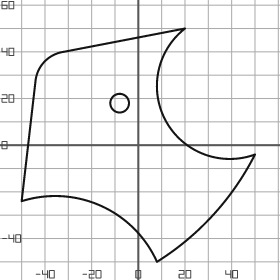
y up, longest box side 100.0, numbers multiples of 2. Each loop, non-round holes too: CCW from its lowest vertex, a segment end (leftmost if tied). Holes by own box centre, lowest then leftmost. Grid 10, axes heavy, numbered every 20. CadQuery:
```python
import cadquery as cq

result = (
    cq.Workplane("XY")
    .moveTo(8.0, -50.0)
    .threePointArc((32.0, -30.0), (50.0, -4.0))
    .threePointArc((12.0, 10.0), (20.0, 50.0))
    .lineTo(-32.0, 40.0)
    .threePointArc((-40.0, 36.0), (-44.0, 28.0))
    .lineTo(-50.0, -24.0)
    .threePointArc((-16.0, -26.0), (8.0, -50.0))
    .close()
    .moveTo(-8.0, 18.0)
    .circle(4.0)
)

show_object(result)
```